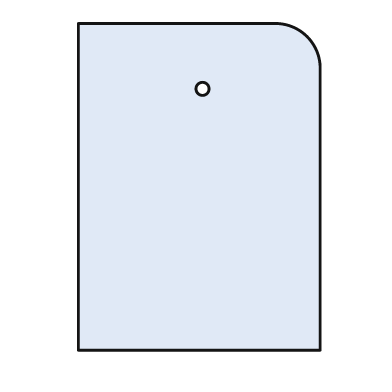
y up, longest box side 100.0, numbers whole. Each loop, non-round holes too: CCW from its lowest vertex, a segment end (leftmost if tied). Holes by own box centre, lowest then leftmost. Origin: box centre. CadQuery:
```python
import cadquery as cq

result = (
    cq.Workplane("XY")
    .moveTo(-37.0, -50.0)
    .lineTo(37.0, -50.0)
    .lineTo(37.0, 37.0)
    .threePointArc((33.0, 46.0), (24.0, 50.0))
    .lineTo(-37.0, 50.0)
    .close()
    .moveTo(1.0, 30.0)
    .circle(2.0)
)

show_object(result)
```